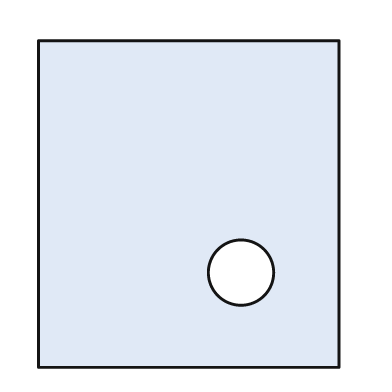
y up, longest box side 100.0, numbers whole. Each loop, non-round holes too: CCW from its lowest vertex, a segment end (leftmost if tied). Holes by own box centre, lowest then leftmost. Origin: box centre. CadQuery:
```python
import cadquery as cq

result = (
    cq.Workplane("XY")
    .moveTo(-46.0, -50.0)
    .lineTo(46.0, -50.0)
    .lineTo(46.0, 50.0)
    .lineTo(-46.0, 50.0)
    .close()
    .moveTo(16.0, -21.0)
    .circle(10.0)
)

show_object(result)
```